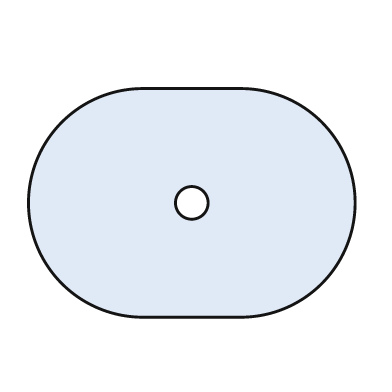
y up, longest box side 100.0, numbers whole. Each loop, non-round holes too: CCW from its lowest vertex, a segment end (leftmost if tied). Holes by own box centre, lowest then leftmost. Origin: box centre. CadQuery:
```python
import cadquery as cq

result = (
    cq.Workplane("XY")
    .moveTo(-15.0, -35.0)
    .lineTo(15.0, -35.0)
    .threePointArc((50.0, 0.0), (15.0, 35.0))
    .lineTo(-15.0, 35.0)
    .threePointArc((-50.0, 0.0), (-15.0, -35.0))
    .close()
    .moveTo(0.0, 0.0)
    .circle(5.0)
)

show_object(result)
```